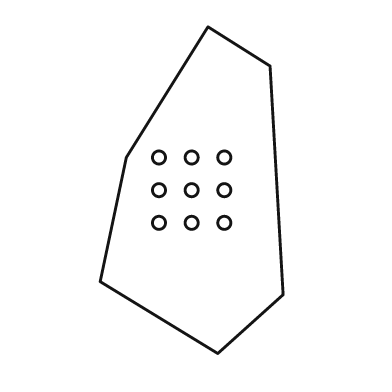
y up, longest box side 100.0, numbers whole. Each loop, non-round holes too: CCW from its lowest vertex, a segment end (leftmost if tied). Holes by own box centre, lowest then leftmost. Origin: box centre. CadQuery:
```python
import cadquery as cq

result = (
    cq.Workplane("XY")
    .moveTo(8.0, -50.0)
    .lineTo(28.0, -32.0)
    .lineTo(24.0, 38.0)
    .lineTo(5.0, 50.0)
    .lineTo(-20.0, 10.0)
    .lineTo(-28.0, -28.0)
    .close()
    .moveTo(-10.0, -10.0)
    .circle(2.0)
    .moveTo(0.0, -10.0)
    .circle(2.0)
    .moveTo(10.0, -10.0)
    .circle(2.0)
    .moveTo(-10.0, 0.0)
    .circle(2.0)
    .moveTo(0.0, 0.0)
    .circle(2.0)
    .moveTo(10.0, 0.0)
    .circle(2.0)
    .moveTo(-10.0, 10.0)
    .circle(2.0)
    .moveTo(0.0, 10.0)
    .circle(2.0)
    .moveTo(10.0, 10.0)
    .circle(2.0)
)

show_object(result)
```